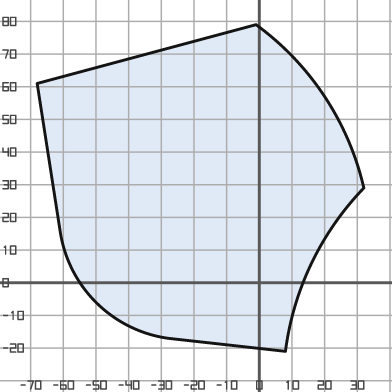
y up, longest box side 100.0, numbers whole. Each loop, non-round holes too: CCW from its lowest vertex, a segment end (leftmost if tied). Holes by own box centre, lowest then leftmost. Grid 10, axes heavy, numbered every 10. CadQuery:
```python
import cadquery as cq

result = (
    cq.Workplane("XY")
    .moveTo(8.0, -21.0)
    .threePointArc((16.0, 6.0), (32.0, 29.0))
    .threePointArc((20.0, 57.0), (-1.0, 79.0))
    .lineTo(-68.0, 61.0)
    .lineTo(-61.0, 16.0)
    .threePointArc((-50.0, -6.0), (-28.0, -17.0))
    .close()
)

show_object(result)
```